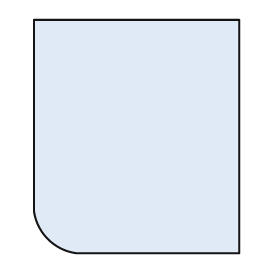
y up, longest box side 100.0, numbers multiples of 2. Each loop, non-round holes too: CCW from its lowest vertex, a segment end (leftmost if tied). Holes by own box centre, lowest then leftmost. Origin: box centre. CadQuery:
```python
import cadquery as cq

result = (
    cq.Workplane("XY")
    .moveTo(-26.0, -50.0)
    .lineTo(44.0, -50.0)
    .lineTo(44.0, 50.0)
    .lineTo(-44.0, 50.0)
    .lineTo(-44.0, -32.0)
    .threePointArc((-38.0, -44.0), (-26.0, -50.0))
    .close()
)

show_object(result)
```